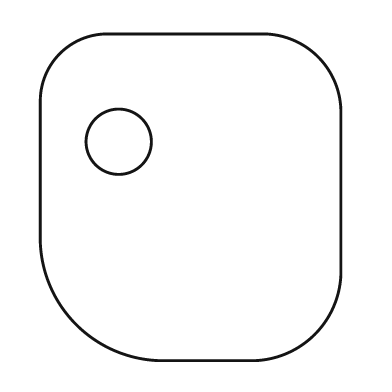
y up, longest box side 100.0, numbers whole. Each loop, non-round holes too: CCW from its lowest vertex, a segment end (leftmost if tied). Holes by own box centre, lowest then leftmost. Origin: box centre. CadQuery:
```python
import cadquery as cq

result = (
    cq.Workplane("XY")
    .moveTo(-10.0, -50.0)
    .lineTo(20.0, -50.0)
    .threePointArc((38.0, -42.0), (46.0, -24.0))
    .lineTo(46.0, 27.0)
    .threePointArc((39.0, 43.0), (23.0, 50.0))
    .lineTo(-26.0, 50.0)
    .threePointArc((-40.0, 44.0), (-46.0, 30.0))
    .lineTo(-46.0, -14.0)
    .threePointArc((-35.0, -39.0), (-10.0, -50.0))
    .close()
    .moveTo(-22.0, 17.0)
    .circle(10.0)
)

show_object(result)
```